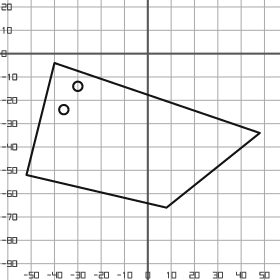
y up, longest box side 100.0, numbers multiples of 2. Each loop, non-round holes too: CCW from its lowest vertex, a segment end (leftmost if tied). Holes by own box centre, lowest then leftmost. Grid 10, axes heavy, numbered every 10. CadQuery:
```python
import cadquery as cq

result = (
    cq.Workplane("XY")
    .moveTo(8.0, -66.0)
    .lineTo(48.0, -34.0)
    .lineTo(-40.0, -4.0)
    .lineTo(-52.0, -52.0)
    .close()
    .moveTo(-36.0, -24.0)
    .circle(2.0)
    .moveTo(-30.0, -14.0)
    .circle(2.0)
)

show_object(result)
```